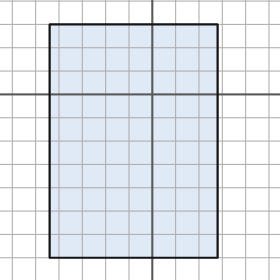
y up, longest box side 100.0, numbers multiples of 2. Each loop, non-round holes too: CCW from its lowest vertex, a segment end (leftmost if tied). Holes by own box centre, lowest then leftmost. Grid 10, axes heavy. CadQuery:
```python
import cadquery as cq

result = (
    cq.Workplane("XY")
    .moveTo(-44.0, -70.0)
    .lineTo(28.0, -70.0)
    .lineTo(28.0, 30.0)
    .lineTo(-44.0, 30.0)
    .close()
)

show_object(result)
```